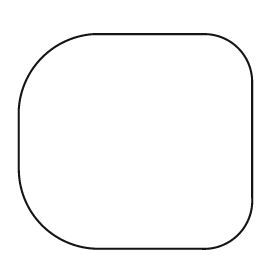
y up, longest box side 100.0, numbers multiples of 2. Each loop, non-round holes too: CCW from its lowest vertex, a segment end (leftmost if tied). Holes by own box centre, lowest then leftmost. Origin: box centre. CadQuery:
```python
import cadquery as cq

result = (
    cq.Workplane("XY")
    .moveTo(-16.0, -46.0)
    .lineTo(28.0, -46.0)
    .threePointArc((44.0, -40.0), (50.0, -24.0))
    .lineTo(50.0, 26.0)
    .threePointArc((44.0, 40.0), (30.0, 46.0))
    .lineTo(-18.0, 46.0)
    .threePointArc((-40.0, 36.0), (-50.0, 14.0))
    .lineTo(-50.0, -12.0)
    .threePointArc((-40.0, -36.0), (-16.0, -46.0))
    .close()
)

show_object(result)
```